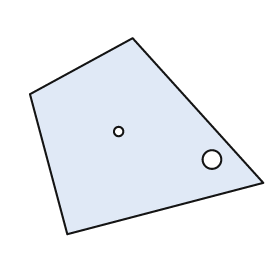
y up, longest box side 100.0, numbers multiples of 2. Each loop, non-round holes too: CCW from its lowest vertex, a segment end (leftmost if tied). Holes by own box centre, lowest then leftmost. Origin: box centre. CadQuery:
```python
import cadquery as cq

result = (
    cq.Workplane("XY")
    .moveTo(-34.0, -42.0)
    .lineTo(50.0, -20.0)
    .lineTo(-6.0, 42.0)
    .lineTo(-50.0, 18.0)
    .close()
    .moveTo(28.0, -10.0)
    .circle(4.0)
    .moveTo(-12.0, 2.0)
    .circle(2.0)
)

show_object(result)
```